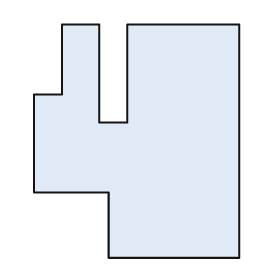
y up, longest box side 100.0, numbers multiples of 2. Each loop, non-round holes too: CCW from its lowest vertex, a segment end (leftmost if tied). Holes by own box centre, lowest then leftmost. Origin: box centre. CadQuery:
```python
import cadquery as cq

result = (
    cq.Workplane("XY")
    .moveTo(-12.0, -50.0)
    .lineTo(44.0, -50.0)
    .lineTo(44.0, 50.0)
    .lineTo(-4.0, 50.0)
    .lineTo(-4.0, 8.0)
    .lineTo(-16.0, 8.0)
    .lineTo(-16.0, 50.0)
    .lineTo(-32.0, 50.0)
    .lineTo(-32.0, 20.0)
    .lineTo(-44.0, 20.0)
    .lineTo(-44.0, -22.0)
    .lineTo(-12.0, -22.0)
    .close()
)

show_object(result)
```